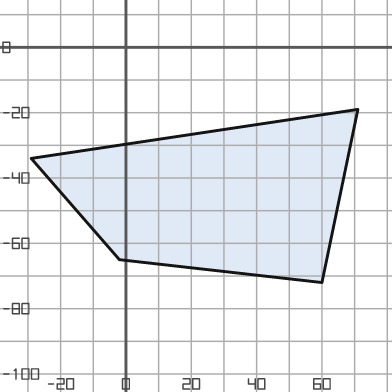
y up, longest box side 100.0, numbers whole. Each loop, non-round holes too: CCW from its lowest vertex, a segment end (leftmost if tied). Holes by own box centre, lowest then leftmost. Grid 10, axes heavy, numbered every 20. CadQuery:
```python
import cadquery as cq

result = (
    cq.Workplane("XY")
    .moveTo(60.0, -72.0)
    .lineTo(71.0, -19.0)
    .lineTo(-29.0, -34.0)
    .lineTo(-2.0, -65.0)
    .close()
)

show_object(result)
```